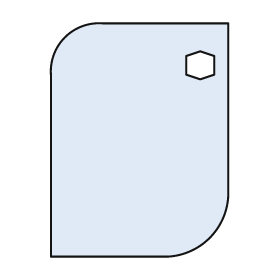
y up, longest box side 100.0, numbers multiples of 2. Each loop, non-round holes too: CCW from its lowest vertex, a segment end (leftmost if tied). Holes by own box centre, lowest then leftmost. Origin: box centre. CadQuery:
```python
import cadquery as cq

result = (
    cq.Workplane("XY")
    .moveTo(-38.0, -50.0)
    .lineTo(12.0, -50.0)
    .threePointArc((30.0, -42.0), (38.0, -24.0))
    .lineTo(38.0, 50.0)
    .lineTo(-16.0, 50.0)
    .threePointArc((-32.0, 44.0), (-38.0, 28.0))
    .close()
    .moveTo(26.0, 26.0)
    .lineTo(32.0, 28.0)
    .lineTo(32.0, 36.0)
    .lineTo(26.0, 38.0)
    .lineTo(20.0, 36.0)
    .lineTo(20.0, 28.0)
    .close()
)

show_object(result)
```